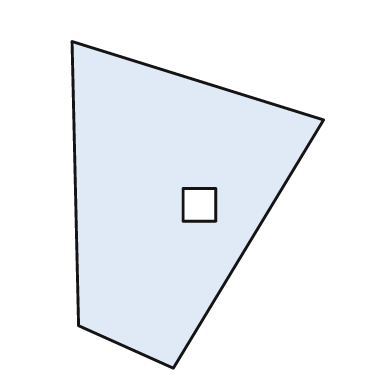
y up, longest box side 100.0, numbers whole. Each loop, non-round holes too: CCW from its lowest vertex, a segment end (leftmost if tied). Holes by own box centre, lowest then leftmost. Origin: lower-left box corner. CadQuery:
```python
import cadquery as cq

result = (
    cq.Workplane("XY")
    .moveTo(31.0, 0.0)
    .lineTo(77.0, 76.0)
    .lineTo(0.0, 100.0)
    .lineTo(2.0, 13.0)
    .close()
    .moveTo(34.0, 45.0)
    .lineTo(44.0, 45.0)
    .lineTo(44.0, 55.0)
    .lineTo(34.0, 55.0)
    .close()
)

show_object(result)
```